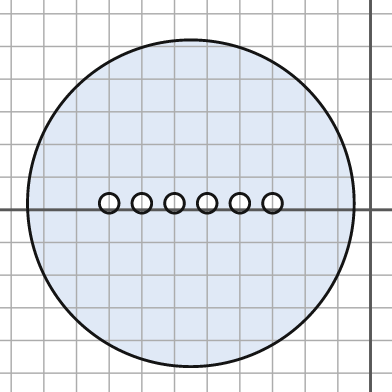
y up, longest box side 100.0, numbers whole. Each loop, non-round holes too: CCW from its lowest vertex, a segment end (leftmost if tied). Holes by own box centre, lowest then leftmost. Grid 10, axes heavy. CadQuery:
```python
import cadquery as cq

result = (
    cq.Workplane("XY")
    .moveTo(-55.0, 2.0)
    .circle(50.0)
    .moveTo(-80.0, 2.0)
    .circle(3.0)
    .moveTo(-70.0, 2.0)
    .circle(3.0)
    .moveTo(-60.0, 2.0)
    .circle(3.0)
    .moveTo(-50.0, 2.0)
    .circle(3.0)
    .moveTo(-40.0, 2.0)
    .circle(3.0)
    .moveTo(-30.0, 2.0)
    .circle(3.0)
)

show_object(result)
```